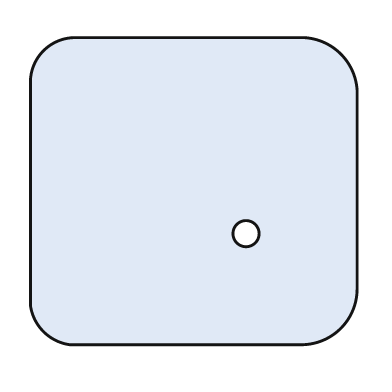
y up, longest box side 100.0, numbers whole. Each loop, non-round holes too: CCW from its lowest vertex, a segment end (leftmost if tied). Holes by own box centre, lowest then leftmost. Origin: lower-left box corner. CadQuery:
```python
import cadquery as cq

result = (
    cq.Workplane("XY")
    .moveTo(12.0, 0.0)
    .lineTo(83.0, 0.0)
    .threePointArc((95.0, 5.0), (100.0, 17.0))
    .lineTo(100.0, 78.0)
    .threePointArc((95.0, 89.0), (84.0, 94.0))
    .lineTo(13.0, 94.0)
    .threePointArc((4.0, 90.0), (0.0, 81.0))
    .lineTo(0.0, 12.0)
    .threePointArc((4.0, 4.0), (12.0, 0.0))
    .close()
    .moveTo(66.0, 34.0)
    .circle(4.0)
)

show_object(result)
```